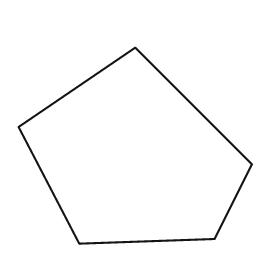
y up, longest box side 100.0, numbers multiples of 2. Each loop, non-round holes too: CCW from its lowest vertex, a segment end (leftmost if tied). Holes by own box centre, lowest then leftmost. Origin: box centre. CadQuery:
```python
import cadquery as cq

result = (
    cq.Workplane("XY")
    .moveTo(-24.0, -42.0)
    .lineTo(34.0, -40.0)
    .lineTo(50.0, -8.0)
    .lineTo(0.0, 42.0)
    .lineTo(-50.0, 8.0)
    .close()
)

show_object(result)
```